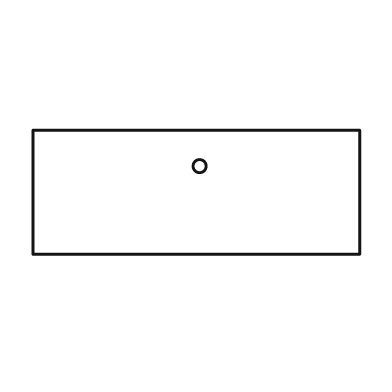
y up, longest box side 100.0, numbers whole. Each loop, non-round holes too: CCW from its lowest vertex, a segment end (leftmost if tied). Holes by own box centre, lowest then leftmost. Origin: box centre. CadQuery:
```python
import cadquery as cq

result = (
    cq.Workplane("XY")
    .moveTo(-50.0, -19.0)
    .lineTo(50.0, -19.0)
    .lineTo(50.0, 19.0)
    .lineTo(-50.0, 19.0)
    .close()
    .moveTo(1.0, 8.0)
    .circle(2.0)
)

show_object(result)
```